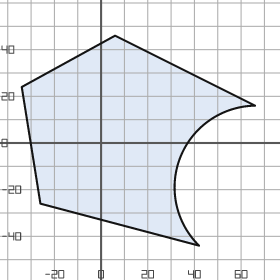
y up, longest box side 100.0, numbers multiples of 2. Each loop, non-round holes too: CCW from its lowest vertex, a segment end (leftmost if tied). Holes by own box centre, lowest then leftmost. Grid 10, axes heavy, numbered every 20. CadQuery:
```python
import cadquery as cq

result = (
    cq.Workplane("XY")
    .moveTo(42.0, -44.0)
    .threePointArc((34.0, -6.0), (66.0, 16.0))
    .lineTo(6.0, 46.0)
    .lineTo(-34.0, 24.0)
    .lineTo(-26.0, -26.0)
    .close()
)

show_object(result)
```